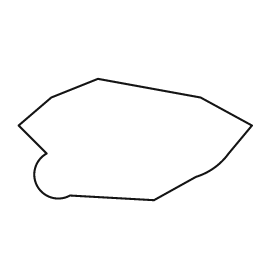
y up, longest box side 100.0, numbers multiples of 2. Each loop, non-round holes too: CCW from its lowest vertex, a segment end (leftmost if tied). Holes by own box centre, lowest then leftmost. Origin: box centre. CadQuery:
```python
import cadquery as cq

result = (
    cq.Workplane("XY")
    .moveTo(8.0, -26.0)
    .lineTo(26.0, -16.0)
    .threePointArc((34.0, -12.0), (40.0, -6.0))
    .lineTo(50.0, 6.0)
    .lineTo(28.0, 18.0)
    .lineTo(-16.0, 26.0)
    .lineTo(-36.0, 18.0)
    .lineTo(-50.0, 6.0)
    .lineTo(-38.0, -6.0)
    .threePointArc((-42.0, -20.0), (-28.0, -24.0))
    .close()
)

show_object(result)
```